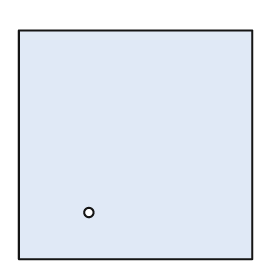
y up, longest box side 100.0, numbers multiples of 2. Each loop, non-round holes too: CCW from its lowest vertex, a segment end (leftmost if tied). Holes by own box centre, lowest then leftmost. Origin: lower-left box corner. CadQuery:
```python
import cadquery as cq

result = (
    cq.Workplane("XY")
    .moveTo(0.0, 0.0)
    .lineTo(100.0, 0.0)
    .lineTo(100.0, 98.0)
    .lineTo(0.0, 98.0)
    .close()
    .moveTo(30.0, 20.0)
    .circle(2.0)
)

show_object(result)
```